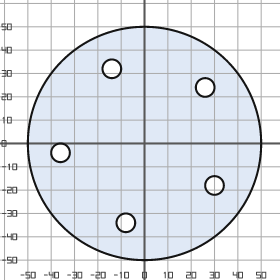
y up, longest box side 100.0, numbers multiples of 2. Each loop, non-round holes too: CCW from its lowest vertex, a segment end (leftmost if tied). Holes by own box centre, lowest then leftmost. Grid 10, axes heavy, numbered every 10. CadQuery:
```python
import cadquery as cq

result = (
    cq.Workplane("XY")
    .moveTo(0.0, 0.0)
    .circle(50.0)
    .moveTo(-8.0, -34.0)
    .circle(4.0)
    .moveTo(30.0, -18.0)
    .circle(4.0)
    .moveTo(-36.0, -4.0)
    .circle(4.0)
    .moveTo(26.0, 24.0)
    .circle(4.0)
    .moveTo(-14.0, 32.0)
    .circle(4.0)
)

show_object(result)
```